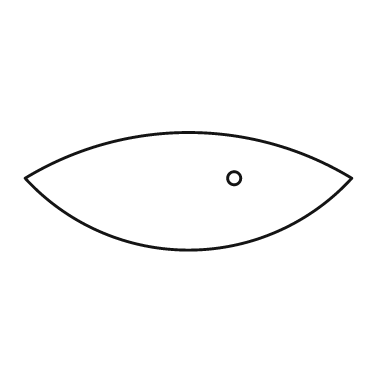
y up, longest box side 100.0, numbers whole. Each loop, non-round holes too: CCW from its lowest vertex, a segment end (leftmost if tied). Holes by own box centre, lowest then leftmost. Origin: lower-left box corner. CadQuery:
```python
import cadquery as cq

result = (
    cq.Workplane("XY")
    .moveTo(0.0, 22.0)
    .threePointArc((50.0, 0.0), (100.0, 22.0))
    .threePointArc((50.0, 36.0), (0.0, 22.0))
    .close()
    .moveTo(64.0, 22.0)
    .circle(2.0)
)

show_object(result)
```